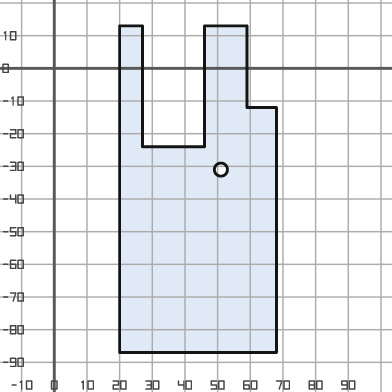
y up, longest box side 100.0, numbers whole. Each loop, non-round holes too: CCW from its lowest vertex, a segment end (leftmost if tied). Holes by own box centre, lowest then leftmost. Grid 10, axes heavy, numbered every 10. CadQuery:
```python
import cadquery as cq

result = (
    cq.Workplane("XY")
    .moveTo(20.0, -87.0)
    .lineTo(68.0, -87.0)
    .lineTo(68.0, -12.0)
    .lineTo(59.0, -12.0)
    .lineTo(59.0, 13.0)
    .lineTo(46.0, 13.0)
    .lineTo(46.0, -24.0)
    .lineTo(27.0, -24.0)
    .lineTo(27.0, 13.0)
    .lineTo(20.0, 13.0)
    .close()
    .moveTo(51.0, -31.0)
    .circle(2.0)
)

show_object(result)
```